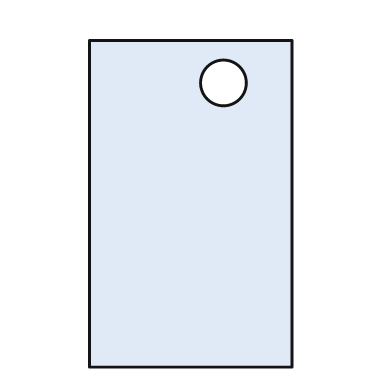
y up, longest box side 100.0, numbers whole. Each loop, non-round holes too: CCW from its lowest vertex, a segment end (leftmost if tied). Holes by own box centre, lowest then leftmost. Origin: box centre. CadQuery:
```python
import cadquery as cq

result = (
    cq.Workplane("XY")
    .moveTo(-31.0, -50.0)
    .lineTo(31.0, -50.0)
    .lineTo(31.0, 50.0)
    .lineTo(-31.0, 50.0)
    .close()
    .moveTo(10.0, 37.0)
    .circle(7.0)
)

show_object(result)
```